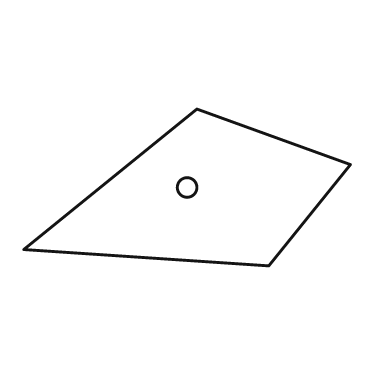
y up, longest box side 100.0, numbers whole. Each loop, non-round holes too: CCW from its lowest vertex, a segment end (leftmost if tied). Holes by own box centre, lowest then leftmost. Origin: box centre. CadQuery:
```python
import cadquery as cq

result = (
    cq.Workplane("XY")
    .moveTo(25.0, -24.0)
    .lineTo(50.0, 7.0)
    .lineTo(3.0, 24.0)
    .lineTo(-50.0, -19.0)
    .close()
    .moveTo(0.0, 0.0)
    .circle(3.0)
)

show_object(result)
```